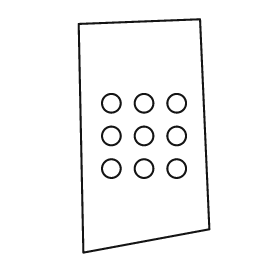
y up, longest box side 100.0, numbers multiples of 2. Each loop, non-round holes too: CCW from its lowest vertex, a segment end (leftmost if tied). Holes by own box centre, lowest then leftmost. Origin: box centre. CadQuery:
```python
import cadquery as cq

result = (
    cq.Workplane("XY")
    .moveTo(-26.0, -50.0)
    .lineTo(28.0, -40.0)
    .lineTo(24.0, 50.0)
    .lineTo(-28.0, 48.0)
    .close()
    .moveTo(-14.0, -14.0)
    .circle(4.0)
    .moveTo(0.0, -14.0)
    .circle(4.0)
    .moveTo(14.0, -14.0)
    .circle(4.0)
    .moveTo(-14.0, 0.0)
    .circle(4.0)
    .moveTo(0.0, 0.0)
    .circle(4.0)
    .moveTo(14.0, 0.0)
    .circle(4.0)
    .moveTo(-14.0, 14.0)
    .circle(4.0)
    .moveTo(0.0, 14.0)
    .circle(4.0)
    .moveTo(14.0, 14.0)
    .circle(4.0)
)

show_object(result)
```